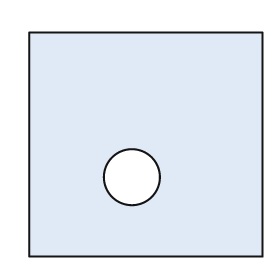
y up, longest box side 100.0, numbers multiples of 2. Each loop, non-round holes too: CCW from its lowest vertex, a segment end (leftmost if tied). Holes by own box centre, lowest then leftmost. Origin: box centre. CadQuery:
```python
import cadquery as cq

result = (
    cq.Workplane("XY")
    .moveTo(-50.0, -48.0)
    .lineTo(50.0, -48.0)
    .lineTo(50.0, 48.0)
    .lineTo(-50.0, 48.0)
    .close()
    .moveTo(-6.0, -14.0)
    .circle(12.0)
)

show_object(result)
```